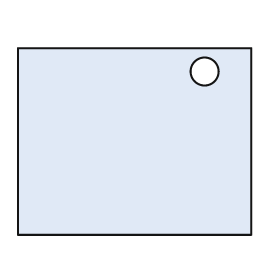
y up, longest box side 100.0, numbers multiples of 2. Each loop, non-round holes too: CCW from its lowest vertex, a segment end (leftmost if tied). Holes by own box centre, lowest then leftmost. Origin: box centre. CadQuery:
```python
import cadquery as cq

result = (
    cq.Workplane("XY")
    .moveTo(-50.0, -40.0)
    .lineTo(50.0, -40.0)
    .lineTo(50.0, 40.0)
    .lineTo(-50.0, 40.0)
    .close()
    .moveTo(30.0, 30.0)
    .circle(6.0)
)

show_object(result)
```